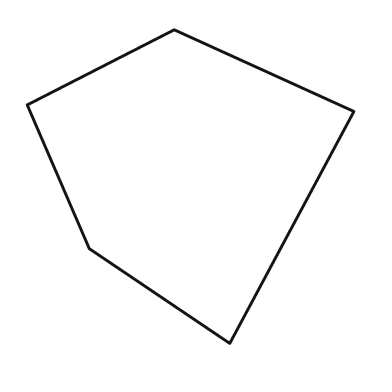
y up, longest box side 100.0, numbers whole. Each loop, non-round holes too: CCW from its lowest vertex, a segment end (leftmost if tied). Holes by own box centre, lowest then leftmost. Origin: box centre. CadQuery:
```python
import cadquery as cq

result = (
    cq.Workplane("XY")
    .moveTo(12.0, -48.0)
    .lineTo(50.0, 23.0)
    .lineTo(-5.0, 48.0)
    .lineTo(-50.0, 25.0)
    .lineTo(-31.0, -19.0)
    .close()
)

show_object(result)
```